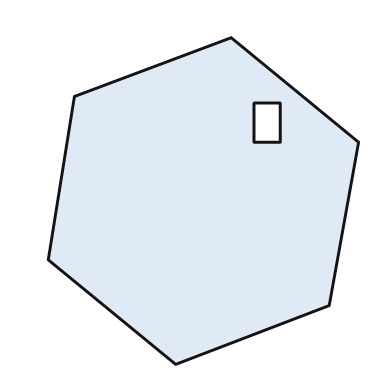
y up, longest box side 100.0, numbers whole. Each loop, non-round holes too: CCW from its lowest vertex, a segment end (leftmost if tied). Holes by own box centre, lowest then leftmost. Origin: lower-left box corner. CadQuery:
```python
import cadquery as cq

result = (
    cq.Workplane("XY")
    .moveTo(39.0, 0.0)
    .lineTo(86.0, 18.0)
    .lineTo(95.0, 68.0)
    .lineTo(56.0, 100.0)
    .lineTo(8.0, 82.0)
    .lineTo(0.0, 32.0)
    .close()
    .moveTo(63.0, 68.0)
    .lineTo(71.0, 68.0)
    .lineTo(71.0, 80.0)
    .lineTo(63.0, 80.0)
    .close()
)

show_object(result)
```